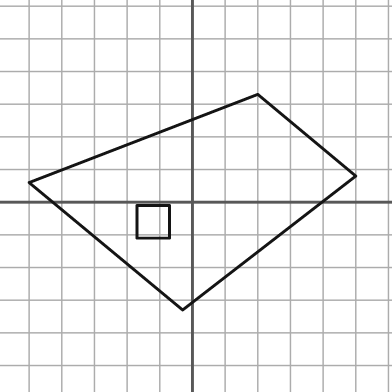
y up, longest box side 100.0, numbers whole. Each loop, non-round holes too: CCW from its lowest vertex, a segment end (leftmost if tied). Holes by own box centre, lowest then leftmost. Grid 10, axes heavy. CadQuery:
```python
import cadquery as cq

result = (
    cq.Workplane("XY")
    .moveTo(-3.0, -33.0)
    .lineTo(50.0, 8.0)
    .lineTo(20.0, 33.0)
    .lineTo(-50.0, 6.0)
    .close()
    .moveTo(-17.0, -11.0)
    .lineTo(-7.0, -11.0)
    .lineTo(-7.0, -1.0)
    .lineTo(-17.0, -1.0)
    .close()
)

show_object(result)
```